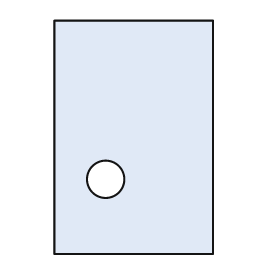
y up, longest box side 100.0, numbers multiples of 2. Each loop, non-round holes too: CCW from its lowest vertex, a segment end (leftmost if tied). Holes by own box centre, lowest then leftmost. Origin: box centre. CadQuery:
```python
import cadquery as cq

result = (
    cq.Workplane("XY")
    .moveTo(-34.0, -50.0)
    .lineTo(34.0, -50.0)
    .lineTo(34.0, 50.0)
    .lineTo(-34.0, 50.0)
    .close()
    .moveTo(-12.0, -18.0)
    .circle(8.0)
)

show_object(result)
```